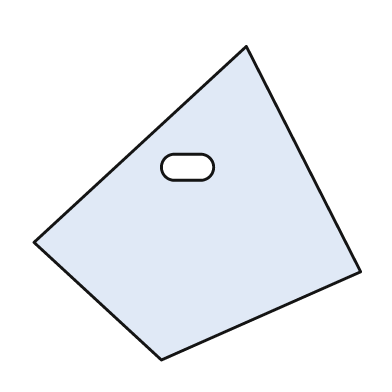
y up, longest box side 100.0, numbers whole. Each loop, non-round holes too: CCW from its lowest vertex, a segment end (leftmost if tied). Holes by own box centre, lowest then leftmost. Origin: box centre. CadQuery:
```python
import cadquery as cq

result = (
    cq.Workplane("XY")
    .moveTo(-11.0, -48.0)
    .lineTo(50.0, -21.0)
    .lineTo(15.0, 48.0)
    .lineTo(-50.0, -12.0)
    .close()
    .moveTo(-7.0, 7.0)
    .lineTo(1.0, 7.0)
    .threePointArc((5.0, 11.0), (1.0, 15.0))
    .lineTo(-7.0, 15.0)
    .threePointArc((-11.0, 11.0), (-7.0, 7.0))
    .close()
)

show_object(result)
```